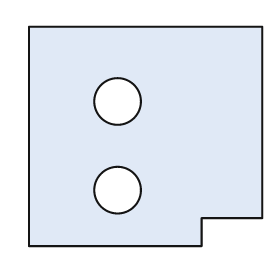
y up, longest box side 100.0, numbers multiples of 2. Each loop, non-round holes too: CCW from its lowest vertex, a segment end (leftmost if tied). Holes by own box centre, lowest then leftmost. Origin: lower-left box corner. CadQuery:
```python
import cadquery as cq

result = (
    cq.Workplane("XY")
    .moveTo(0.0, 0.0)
    .lineTo(74.0, 0.0)
    .lineTo(74.0, 12.0)
    .lineTo(100.0, 12.0)
    .lineTo(100.0, 94.0)
    .lineTo(0.0, 94.0)
    .close()
    .moveTo(38.0, 24.0)
    .circle(10.0)
    .moveTo(38.0, 62.0)
    .circle(10.0)
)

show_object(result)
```